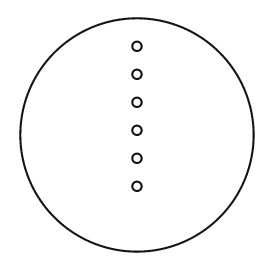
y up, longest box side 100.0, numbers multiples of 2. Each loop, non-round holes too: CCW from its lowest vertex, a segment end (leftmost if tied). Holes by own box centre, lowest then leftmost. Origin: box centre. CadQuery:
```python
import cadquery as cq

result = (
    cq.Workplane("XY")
    .moveTo(0.0, 0.0)
    .circle(50.0)
    .moveTo(0.0, -22.0)
    .circle(2.0)
    .moveTo(0.0, -10.0)
    .circle(2.0)
    .moveTo(0.0, 2.0)
    .circle(2.0)
    .moveTo(0.0, 14.0)
    .circle(2.0)
    .moveTo(0.0, 26.0)
    .circle(2.0)
    .moveTo(0.0, 38.0)
    .circle(2.0)
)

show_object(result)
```